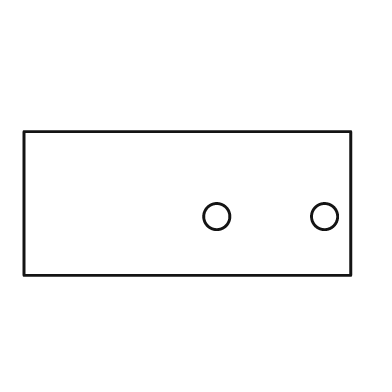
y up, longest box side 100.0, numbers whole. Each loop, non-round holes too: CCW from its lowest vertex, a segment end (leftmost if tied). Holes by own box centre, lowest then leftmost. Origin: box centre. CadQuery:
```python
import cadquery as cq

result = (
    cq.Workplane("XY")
    .moveTo(-50.0, -22.0)
    .lineTo(50.0, -22.0)
    .lineTo(50.0, 22.0)
    .lineTo(-50.0, 22.0)
    .close()
    .moveTo(9.0, -4.0)
    .circle(4.0)
    .moveTo(42.0, -4.0)
    .circle(4.0)
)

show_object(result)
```